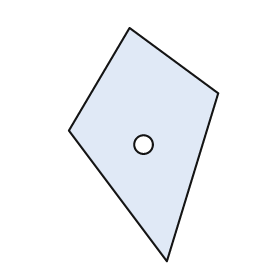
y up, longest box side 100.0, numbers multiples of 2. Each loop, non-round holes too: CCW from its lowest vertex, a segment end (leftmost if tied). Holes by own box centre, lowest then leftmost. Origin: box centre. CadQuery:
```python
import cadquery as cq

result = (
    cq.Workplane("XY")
    .moveTo(10.0, -50.0)
    .lineTo(32.0, 22.0)
    .lineTo(-6.0, 50.0)
    .lineTo(-32.0, 6.0)
    .close()
    .moveTo(0.0, 0.0)
    .circle(4.0)
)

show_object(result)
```